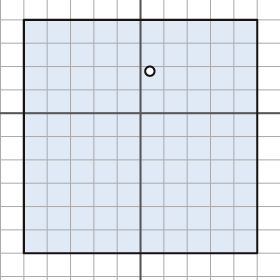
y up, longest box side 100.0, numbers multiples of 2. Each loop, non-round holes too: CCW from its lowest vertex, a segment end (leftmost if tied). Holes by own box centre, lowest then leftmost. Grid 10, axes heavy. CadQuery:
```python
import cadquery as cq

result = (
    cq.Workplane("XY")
    .moveTo(-50.0, -60.0)
    .lineTo(50.0, -60.0)
    .lineTo(50.0, 40.0)
    .lineTo(-50.0, 40.0)
    .close()
    .moveTo(4.0, 18.0)
    .circle(2.0)
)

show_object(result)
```